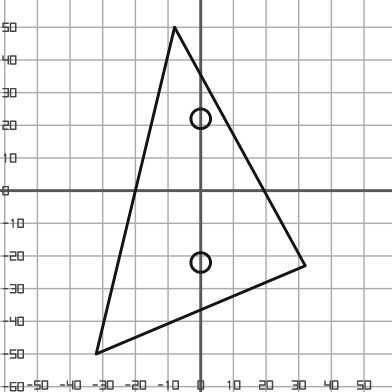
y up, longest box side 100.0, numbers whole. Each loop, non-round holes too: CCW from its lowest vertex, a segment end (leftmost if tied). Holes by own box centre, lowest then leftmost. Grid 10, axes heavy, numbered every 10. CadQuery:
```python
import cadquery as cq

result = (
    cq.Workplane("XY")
    .moveTo(-32.0, -50.0)
    .lineTo(32.0, -23.0)
    .lineTo(-8.0, 50.0)
    .close()
    .moveTo(0.0, -22.0)
    .circle(3.0)
    .moveTo(0.0, 22.0)
    .circle(3.0)
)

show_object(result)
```